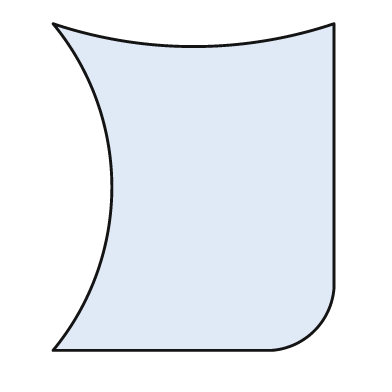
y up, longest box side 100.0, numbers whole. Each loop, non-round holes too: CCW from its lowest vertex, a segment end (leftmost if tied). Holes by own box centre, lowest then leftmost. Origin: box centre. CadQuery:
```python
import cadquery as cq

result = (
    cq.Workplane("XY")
    .moveTo(-43.0, -50.0)
    .lineTo(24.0, -50.0)
    .threePointArc((37.0, -44.0), (43.0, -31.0))
    .lineTo(43.0, 50.0)
    .threePointArc((0.0, 43.0), (-43.0, 50.0))
    .threePointArc((-25.0, 0.0), (-43.0, -50.0))
    .close()
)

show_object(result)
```